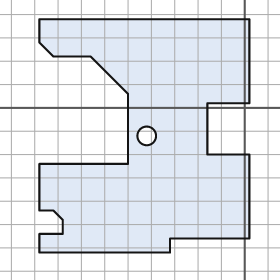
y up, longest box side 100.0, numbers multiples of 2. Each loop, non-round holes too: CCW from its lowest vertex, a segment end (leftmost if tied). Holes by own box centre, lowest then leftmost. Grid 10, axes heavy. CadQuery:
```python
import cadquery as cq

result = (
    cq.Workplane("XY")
    .moveTo(-88.0, -62.0)
    .lineTo(-32.0, -62.0)
    .lineTo(-32.0, -56.0)
    .lineTo(2.0, -56.0)
    .lineTo(2.0, -20.0)
    .lineTo(-16.0, -20.0)
    .lineTo(-16.0, 2.0)
    .lineTo(2.0, 2.0)
    .lineTo(2.0, 38.0)
    .lineTo(-88.0, 38.0)
    .lineTo(-88.0, 28.0)
    .lineTo(-82.0, 22.0)
    .lineTo(-66.0, 22.0)
    .lineTo(-50.0, 6.0)
    .lineTo(-50.0, -24.0)
    .lineTo(-88.0, -24.0)
    .lineTo(-88.0, -44.0)
    .lineTo(-82.0, -44.0)
    .lineTo(-78.0, -48.0)
    .lineTo(-78.0, -54.0)
    .lineTo(-88.0, -54.0)
    .close()
    .moveTo(-42.0, -12.0)
    .circle(4.0)
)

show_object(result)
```